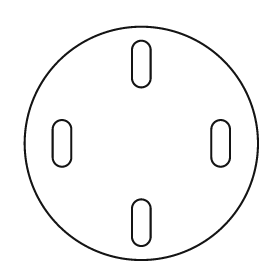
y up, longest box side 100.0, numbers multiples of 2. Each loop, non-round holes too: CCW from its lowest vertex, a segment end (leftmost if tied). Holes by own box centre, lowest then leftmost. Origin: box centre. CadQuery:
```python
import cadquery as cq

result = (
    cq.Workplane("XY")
    .moveTo(0.0, 0.0)
    .circle(50.0)
    .moveTo(-4.0, -40.0)
    .threePointArc((0.0, -44.0), (4.0, -40.0))
    .lineTo(4.0, -28.0)
    .threePointArc((0.0, -24.0), (-4.0, -28.0))
    .close()
    .moveTo(-38.0, -6.0)
    .threePointArc((-34.0, -10.0), (-30.0, -6.0))
    .lineTo(-30.0, 6.0)
    .threePointArc((-34.0, 10.0), (-38.0, 6.0))
    .close()
    .moveTo(30.0, -6.0)
    .threePointArc((34.0, -10.0), (38.0, -6.0))
    .lineTo(38.0, 6.0)
    .threePointArc((34.0, 10.0), (30.0, 6.0))
    .close()
    .moveTo(-4.0, 28.0)
    .threePointArc((0.0, 24.0), (4.0, 28.0))
    .lineTo(4.0, 40.0)
    .threePointArc((0.0, 44.0), (-4.0, 40.0))
    .close()
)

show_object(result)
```